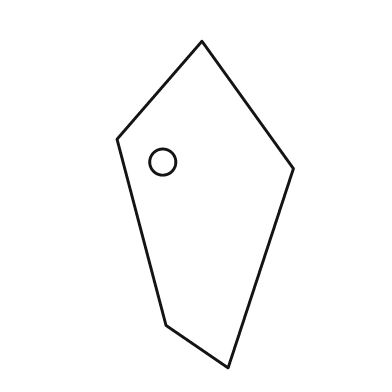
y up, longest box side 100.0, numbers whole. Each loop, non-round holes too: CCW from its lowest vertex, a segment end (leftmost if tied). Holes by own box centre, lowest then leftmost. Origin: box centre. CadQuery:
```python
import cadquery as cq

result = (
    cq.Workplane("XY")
    .moveTo(7.0, -50.0)
    .lineTo(27.0, 11.0)
    .lineTo(-1.0, 50.0)
    .lineTo(-27.0, 20.0)
    .lineTo(-12.0, -37.0)
    .close()
    .moveTo(-13.0, 13.0)
    .circle(4.0)
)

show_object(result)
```